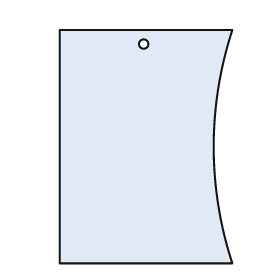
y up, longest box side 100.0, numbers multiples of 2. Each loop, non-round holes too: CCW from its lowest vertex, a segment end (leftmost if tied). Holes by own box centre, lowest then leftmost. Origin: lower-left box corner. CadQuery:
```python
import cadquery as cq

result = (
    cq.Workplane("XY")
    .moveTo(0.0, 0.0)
    .lineTo(74.0, 0.0)
    .threePointArc((66.0, 50.0), (74.0, 100.0))
    .lineTo(0.0, 100.0)
    .close()
    .moveTo(36.0, 94.0)
    .circle(2.0)
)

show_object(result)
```